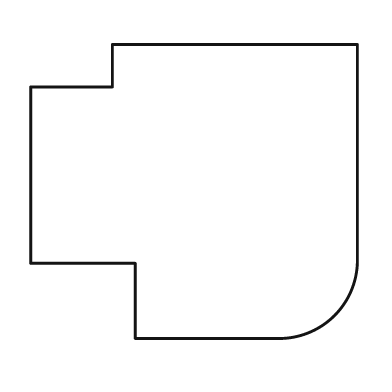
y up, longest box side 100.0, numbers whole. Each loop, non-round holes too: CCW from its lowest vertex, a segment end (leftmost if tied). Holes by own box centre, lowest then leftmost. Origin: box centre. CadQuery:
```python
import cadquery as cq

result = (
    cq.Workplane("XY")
    .moveTo(-18.0, -45.0)
    .lineTo(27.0, -45.0)
    .threePointArc((43.0, -38.0), (50.0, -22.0))
    .lineTo(50.0, 45.0)
    .lineTo(-25.0, 45.0)
    .lineTo(-25.0, 32.0)
    .lineTo(-50.0, 32.0)
    .lineTo(-50.0, -22.0)
    .lineTo(-18.0, -22.0)
    .close()
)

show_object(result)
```